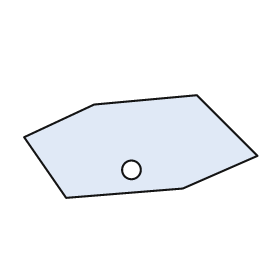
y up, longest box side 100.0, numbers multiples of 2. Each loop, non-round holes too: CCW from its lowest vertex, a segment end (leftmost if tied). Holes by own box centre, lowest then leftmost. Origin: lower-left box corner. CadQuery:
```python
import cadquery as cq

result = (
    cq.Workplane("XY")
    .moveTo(18.0, 0.0)
    .lineTo(68.0, 4.0)
    .lineTo(100.0, 18.0)
    .lineTo(74.0, 44.0)
    .lineTo(30.0, 40.0)
    .lineTo(0.0, 26.0)
    .close()
    .moveTo(46.0, 12.0)
    .circle(4.0)
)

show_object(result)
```